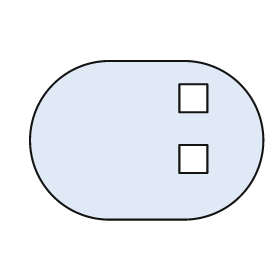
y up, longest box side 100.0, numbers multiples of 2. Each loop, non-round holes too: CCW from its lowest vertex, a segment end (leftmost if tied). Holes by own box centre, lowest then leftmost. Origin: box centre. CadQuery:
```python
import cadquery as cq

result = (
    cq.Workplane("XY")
    .moveTo(-16.0, -34.0)
    .lineTo(16.0, -34.0)
    .threePointArc((50.0, 0.0), (16.0, 34.0))
    .lineTo(-16.0, 34.0)
    .threePointArc((-50.0, 0.0), (-16.0, -34.0))
    .close()
    .moveTo(14.0, -14.0)
    .lineTo(26.0, -14.0)
    .lineTo(26.0, -2.0)
    .lineTo(14.0, -2.0)
    .close()
    .moveTo(14.0, 12.0)
    .lineTo(26.0, 12.0)
    .lineTo(26.0, 24.0)
    .lineTo(14.0, 24.0)
    .close()
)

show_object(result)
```